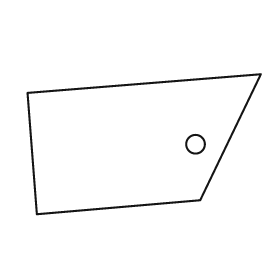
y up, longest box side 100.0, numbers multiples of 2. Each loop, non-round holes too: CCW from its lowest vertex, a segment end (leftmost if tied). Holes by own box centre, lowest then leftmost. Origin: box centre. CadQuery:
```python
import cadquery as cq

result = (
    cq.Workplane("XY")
    .moveTo(-46.0, -30.0)
    .lineTo(24.0, -24.0)
    .lineTo(50.0, 30.0)
    .lineTo(-50.0, 22.0)
    .close()
    .moveTo(22.0, 0.0)
    .circle(4.0)
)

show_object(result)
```